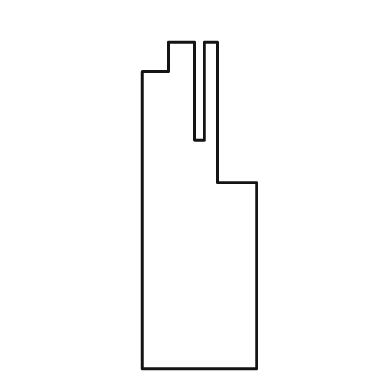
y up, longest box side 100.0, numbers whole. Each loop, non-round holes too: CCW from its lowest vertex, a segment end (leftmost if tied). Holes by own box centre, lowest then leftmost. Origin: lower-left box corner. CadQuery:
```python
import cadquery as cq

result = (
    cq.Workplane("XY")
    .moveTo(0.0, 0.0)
    .lineTo(35.0, 0.0)
    .lineTo(35.0, 57.0)
    .lineTo(23.0, 57.0)
    .lineTo(23.0, 100.0)
    .lineTo(19.0, 100.0)
    .lineTo(19.0, 70.0)
    .lineTo(16.0, 70.0)
    .lineTo(16.0, 100.0)
    .lineTo(8.0, 100.0)
    .lineTo(8.0, 91.0)
    .lineTo(0.0, 91.0)
    .close()
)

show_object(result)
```